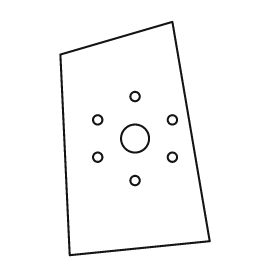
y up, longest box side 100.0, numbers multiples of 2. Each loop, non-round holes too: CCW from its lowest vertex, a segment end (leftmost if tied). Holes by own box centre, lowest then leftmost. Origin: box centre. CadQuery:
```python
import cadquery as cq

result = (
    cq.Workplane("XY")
    .moveTo(-28.0, -50.0)
    .lineTo(32.0, -44.0)
    .lineTo(16.0, 50.0)
    .lineTo(-32.0, 36.0)
    .close()
    .moveTo(0.0, -18.0)
    .circle(2.0)
    .moveTo(-16.0, -8.0)
    .circle(2.0)
    .moveTo(16.0, -8.0)
    .circle(2.0)
    .moveTo(0.0, 0.0)
    .circle(6.0)
    .moveTo(-16.0, 8.0)
    .circle(2.0)
    .moveTo(16.0, 8.0)
    .circle(2.0)
    .moveTo(0.0, 18.0)
    .circle(2.0)
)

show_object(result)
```